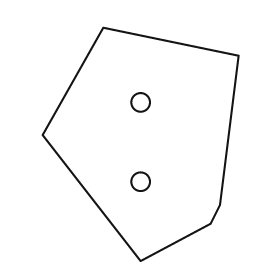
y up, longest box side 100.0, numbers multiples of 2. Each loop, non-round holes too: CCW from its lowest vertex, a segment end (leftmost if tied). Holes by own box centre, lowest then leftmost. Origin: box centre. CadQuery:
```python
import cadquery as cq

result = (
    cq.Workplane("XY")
    .moveTo(0.0, -50.0)
    .lineTo(30.0, -34.0)
    .lineTo(34.0, -26.0)
    .lineTo(42.0, 38.0)
    .lineTo(-16.0, 50.0)
    .lineTo(-42.0, 4.0)
    .close()
    .moveTo(0.0, -16.0)
    .circle(4.0)
    .moveTo(0.0, 18.0)
    .circle(4.0)
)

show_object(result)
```